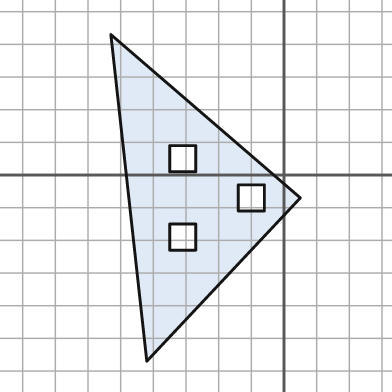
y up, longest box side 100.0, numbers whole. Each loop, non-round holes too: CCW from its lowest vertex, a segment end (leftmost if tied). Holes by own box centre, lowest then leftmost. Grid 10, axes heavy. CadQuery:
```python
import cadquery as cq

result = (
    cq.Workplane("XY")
    .moveTo(-42.0, -57.0)
    .lineTo(5.0, -7.0)
    .lineTo(-53.0, 43.0)
    .close()
    .moveTo(-35.0, -23.0)
    .lineTo(-27.0, -23.0)
    .lineTo(-27.0, -15.0)
    .lineTo(-35.0, -15.0)
    .close()
    .moveTo(-14.0, -11.0)
    .lineTo(-6.0, -11.0)
    .lineTo(-6.0, -3.0)
    .lineTo(-14.0, -3.0)
    .close()
    .moveTo(-35.0, 1.0)
    .lineTo(-27.0, 1.0)
    .lineTo(-27.0, 9.0)
    .lineTo(-35.0, 9.0)
    .close()
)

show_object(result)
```